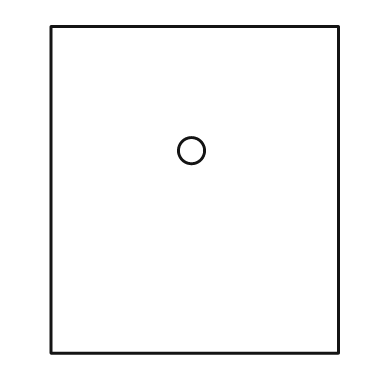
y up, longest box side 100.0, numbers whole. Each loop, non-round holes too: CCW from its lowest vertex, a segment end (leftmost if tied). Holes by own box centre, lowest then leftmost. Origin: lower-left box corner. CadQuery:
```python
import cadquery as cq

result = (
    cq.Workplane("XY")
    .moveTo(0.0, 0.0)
    .lineTo(88.0, 0.0)
    .lineTo(88.0, 100.0)
    .lineTo(0.0, 100.0)
    .close()
    .moveTo(43.0, 62.0)
    .circle(4.0)
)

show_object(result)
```